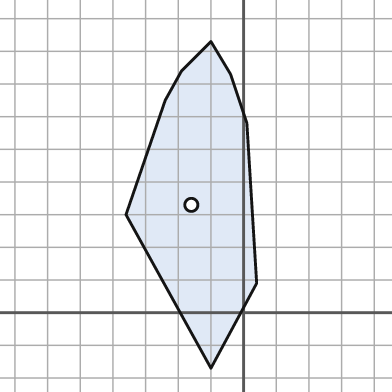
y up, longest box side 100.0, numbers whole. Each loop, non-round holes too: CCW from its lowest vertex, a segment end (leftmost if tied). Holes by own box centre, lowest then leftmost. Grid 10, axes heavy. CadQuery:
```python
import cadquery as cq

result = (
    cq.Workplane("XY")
    .moveTo(-10.0, -17.0)
    .lineTo(4.0, 9.0)
    .lineTo(1.0, 58.0)
    .lineTo(-4.0, 73.0)
    .lineTo(-10.0, 83.0)
    .lineTo(-19.0, 74.0)
    .lineTo(-24.0, 65.0)
    .lineTo(-36.0, 30.0)
    .close()
    .moveTo(-16.0, 33.0)
    .circle(2.0)
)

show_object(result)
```